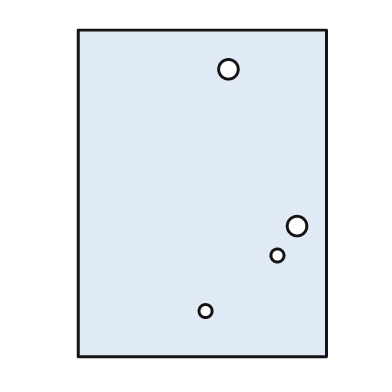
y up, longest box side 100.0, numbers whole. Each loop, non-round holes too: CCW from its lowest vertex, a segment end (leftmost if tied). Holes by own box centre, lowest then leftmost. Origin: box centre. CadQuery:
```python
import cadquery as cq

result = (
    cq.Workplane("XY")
    .moveTo(-38.0, -50.0)
    .lineTo(38.0, -50.0)
    .lineTo(38.0, 50.0)
    .lineTo(-38.0, 50.0)
    .close()
    .moveTo(1.0, -36.0)
    .circle(2.0)
    .moveTo(23.0, -19.0)
    .circle(2.0)
    .moveTo(29.0, -10.0)
    .circle(3.0)
    .moveTo(8.0, 38.0)
    .circle(3.0)
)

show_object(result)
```